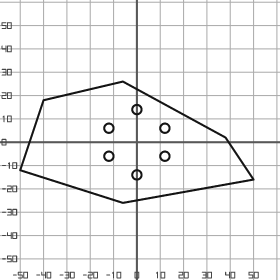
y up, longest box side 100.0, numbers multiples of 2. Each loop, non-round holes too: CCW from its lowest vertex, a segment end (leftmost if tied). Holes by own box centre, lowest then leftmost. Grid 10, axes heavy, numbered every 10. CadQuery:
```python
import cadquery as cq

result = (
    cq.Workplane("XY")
    .moveTo(-6.0, -26.0)
    .lineTo(50.0, -16.0)
    .lineTo(38.0, 2.0)
    .lineTo(-6.0, 26.0)
    .lineTo(-40.0, 18.0)
    .lineTo(-50.0, -12.0)
    .close()
    .moveTo(0.0, -14.0)
    .circle(2.0)
    .moveTo(-12.0, -6.0)
    .circle(2.0)
    .moveTo(12.0, -6.0)
    .circle(2.0)
    .moveTo(-12.0, 6.0)
    .circle(2.0)
    .moveTo(12.0, 6.0)
    .circle(2.0)
    .moveTo(0.0, 14.0)
    .circle(2.0)
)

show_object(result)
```